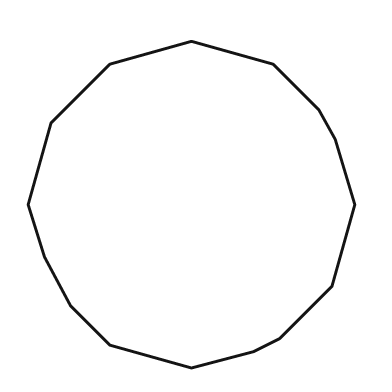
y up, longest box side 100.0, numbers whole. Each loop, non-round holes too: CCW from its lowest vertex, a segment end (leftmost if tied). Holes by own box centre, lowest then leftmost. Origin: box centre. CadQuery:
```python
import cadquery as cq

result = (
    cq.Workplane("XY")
    .moveTo(0.0, -50.0)
    .lineTo(19.0, -45.0)
    .lineTo(27.0, -41.0)
    .lineTo(43.0, -25.0)
    .lineTo(50.0, 0.0)
    .lineTo(44.0, 20.0)
    .lineTo(39.0, 29.0)
    .lineTo(25.0, 43.0)
    .lineTo(0.0, 50.0)
    .lineTo(-25.0, 43.0)
    .lineTo(-43.0, 25.0)
    .lineTo(-50.0, 0.0)
    .lineTo(-45.0, -16.0)
    .lineTo(-37.0, -31.0)
    .lineTo(-25.0, -43.0)
    .close()
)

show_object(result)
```